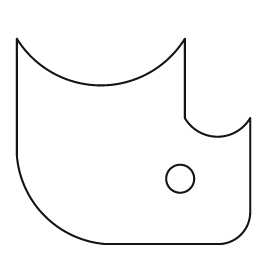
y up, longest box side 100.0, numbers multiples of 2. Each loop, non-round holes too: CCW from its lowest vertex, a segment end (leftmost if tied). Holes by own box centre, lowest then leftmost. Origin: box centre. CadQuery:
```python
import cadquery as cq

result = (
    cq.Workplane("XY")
    .moveTo(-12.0, -44.0)
    .lineTo(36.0, -44.0)
    .threePointArc((46.0, -40.0), (50.0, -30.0))
    .lineTo(50.0, 10.0)
    .threePointArc((36.0, 2.0), (22.0, 10.0))
    .lineTo(22.0, 44.0)
    .threePointArc((-14.0, 24.0), (-50.0, 44.0))
    .lineTo(-50.0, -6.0)
    .threePointArc((-38.0, -32.0), (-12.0, -44.0))
    .close()
    .moveTo(20.0, -16.0)
    .circle(6.0)
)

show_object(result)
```